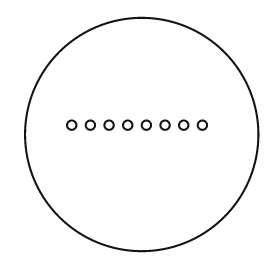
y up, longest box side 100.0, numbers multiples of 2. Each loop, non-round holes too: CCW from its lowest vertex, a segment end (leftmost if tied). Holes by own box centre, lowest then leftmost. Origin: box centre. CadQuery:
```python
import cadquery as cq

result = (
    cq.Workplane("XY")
    .moveTo(0.0, 0.0)
    .circle(50.0)
    .moveTo(-30.0, 4.0)
    .circle(2.0)
    .moveTo(-22.0, 4.0)
    .circle(2.0)
    .moveTo(-14.0, 4.0)
    .circle(2.0)
    .moveTo(-6.0, 4.0)
    .circle(2.0)
    .moveTo(2.0, 4.0)
    .circle(2.0)
    .moveTo(10.0, 4.0)
    .circle(2.0)
    .moveTo(18.0, 4.0)
    .circle(2.0)
    .moveTo(26.0, 4.0)
    .circle(2.0)
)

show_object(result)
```